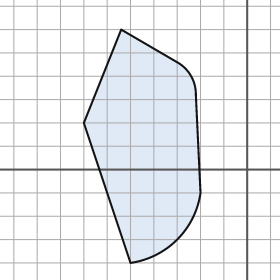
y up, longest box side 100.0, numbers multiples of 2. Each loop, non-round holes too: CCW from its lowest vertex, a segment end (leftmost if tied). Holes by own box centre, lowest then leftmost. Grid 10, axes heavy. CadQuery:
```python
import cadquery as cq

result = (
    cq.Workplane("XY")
    .moveTo(-50.0, -40.0)
    .threePointArc((-30.0, -30.0), (-20.0, -10.0))
    .lineTo(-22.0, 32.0)
    .threePointArc((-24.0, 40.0), (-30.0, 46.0))
    .lineTo(-54.0, 60.0)
    .lineTo(-70.0, 20.0)
    .close()
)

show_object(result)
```